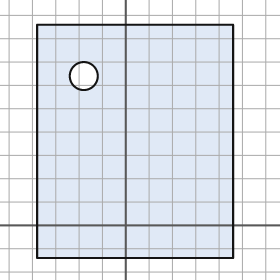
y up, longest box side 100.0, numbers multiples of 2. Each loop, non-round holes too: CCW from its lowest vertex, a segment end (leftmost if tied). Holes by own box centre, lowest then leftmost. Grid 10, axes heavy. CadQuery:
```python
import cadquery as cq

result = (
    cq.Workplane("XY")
    .moveTo(-38.0, -14.0)
    .lineTo(46.0, -14.0)
    .lineTo(46.0, 86.0)
    .lineTo(-38.0, 86.0)
    .close()
    .moveTo(-18.0, 64.0)
    .circle(6.0)
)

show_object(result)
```